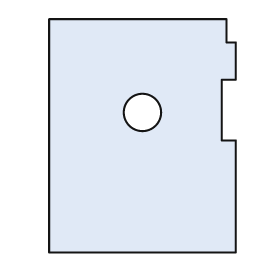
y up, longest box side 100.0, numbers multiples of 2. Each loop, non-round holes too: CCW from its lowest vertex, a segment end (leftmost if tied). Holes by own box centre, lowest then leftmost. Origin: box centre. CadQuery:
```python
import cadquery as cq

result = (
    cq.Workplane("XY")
    .moveTo(-40.0, -50.0)
    .lineTo(40.0, -50.0)
    .lineTo(40.0, -2.0)
    .lineTo(34.0, -2.0)
    .lineTo(34.0, 24.0)
    .lineTo(40.0, 24.0)
    .lineTo(40.0, 40.0)
    .lineTo(36.0, 40.0)
    .lineTo(36.0, 50.0)
    .lineTo(-40.0, 50.0)
    .close()
    .moveTo(0.0, 10.0)
    .circle(8.0)
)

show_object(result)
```